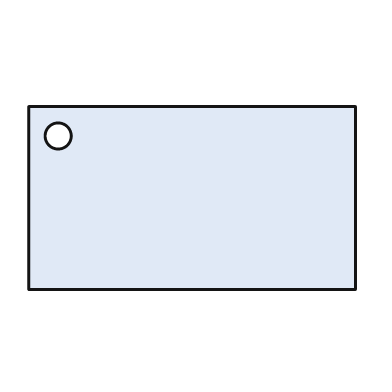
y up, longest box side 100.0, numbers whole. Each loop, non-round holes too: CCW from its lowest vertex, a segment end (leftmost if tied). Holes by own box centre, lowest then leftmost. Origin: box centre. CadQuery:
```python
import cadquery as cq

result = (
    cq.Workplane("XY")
    .moveTo(-50.0, -28.0)
    .lineTo(50.0, -28.0)
    .lineTo(50.0, 28.0)
    .lineTo(-50.0, 28.0)
    .close()
    .moveTo(-41.0, 19.0)
    .circle(4.0)
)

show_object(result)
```